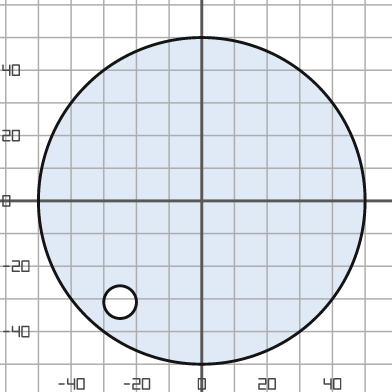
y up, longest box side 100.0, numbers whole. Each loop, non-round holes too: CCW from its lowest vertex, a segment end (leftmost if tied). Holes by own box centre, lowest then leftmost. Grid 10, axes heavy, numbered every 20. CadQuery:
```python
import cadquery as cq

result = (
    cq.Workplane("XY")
    .moveTo(0.0, 0.0)
    .circle(50.0)
    .moveTo(-25.0, -31.0)
    .circle(5.0)
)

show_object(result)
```